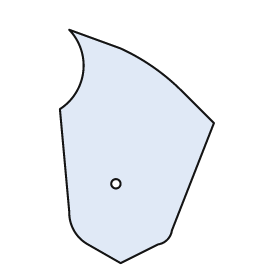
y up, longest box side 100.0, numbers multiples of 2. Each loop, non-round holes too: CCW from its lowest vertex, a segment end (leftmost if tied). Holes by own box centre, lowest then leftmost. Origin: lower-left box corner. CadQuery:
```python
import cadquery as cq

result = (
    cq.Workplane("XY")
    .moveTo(26.0, 0.0)
    .lineTo(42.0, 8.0)
    .threePointArc((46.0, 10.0), (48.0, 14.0))
    .lineTo(66.0, 60.0)
    .lineTo(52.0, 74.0)
    .threePointArc((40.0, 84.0), (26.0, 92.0))
    .lineTo(4.0, 100.0)
    .threePointArc((10.0, 82.0), (0.0, 66.0))
    .lineTo(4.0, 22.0)
    .threePointArc((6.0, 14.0), (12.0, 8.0))
    .close()
    .moveTo(24.0, 34.0)
    .circle(2.0)
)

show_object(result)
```